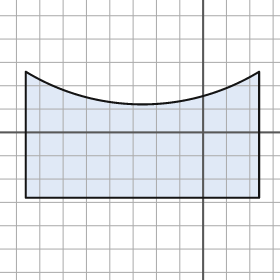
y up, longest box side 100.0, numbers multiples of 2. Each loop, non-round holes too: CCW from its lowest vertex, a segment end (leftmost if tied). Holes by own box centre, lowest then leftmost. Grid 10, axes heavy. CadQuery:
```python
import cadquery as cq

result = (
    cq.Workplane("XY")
    .moveTo(-76.0, -28.0)
    .lineTo(24.0, -28.0)
    .lineTo(24.0, 26.0)
    .threePointArc((-26.0, 12.0), (-76.0, 26.0))
    .close()
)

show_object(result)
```